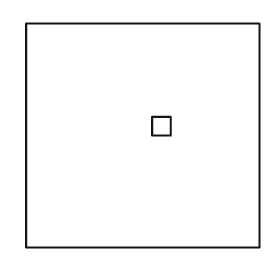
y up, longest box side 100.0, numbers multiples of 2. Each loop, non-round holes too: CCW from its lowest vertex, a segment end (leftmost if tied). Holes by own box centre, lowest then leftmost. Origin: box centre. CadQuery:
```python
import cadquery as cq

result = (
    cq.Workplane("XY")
    .moveTo(-50.0, -48.0)
    .lineTo(50.0, -48.0)
    .lineTo(50.0, 48.0)
    .lineTo(-50.0, 48.0)
    .close()
    .moveTo(4.0, 0.0)
    .lineTo(12.0, 0.0)
    .lineTo(12.0, 8.0)
    .lineTo(4.0, 8.0)
    .close()
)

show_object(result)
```